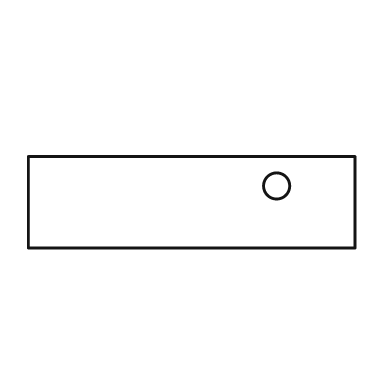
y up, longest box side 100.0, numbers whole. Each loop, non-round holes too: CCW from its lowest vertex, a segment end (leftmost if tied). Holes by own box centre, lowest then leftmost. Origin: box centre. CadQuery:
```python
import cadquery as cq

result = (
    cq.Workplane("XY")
    .moveTo(-50.0, -14.0)
    .lineTo(50.0, -14.0)
    .lineTo(50.0, 14.0)
    .lineTo(-50.0, 14.0)
    .close()
    .moveTo(26.0, 5.0)
    .circle(4.0)
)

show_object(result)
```